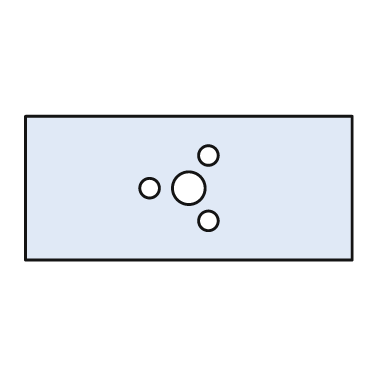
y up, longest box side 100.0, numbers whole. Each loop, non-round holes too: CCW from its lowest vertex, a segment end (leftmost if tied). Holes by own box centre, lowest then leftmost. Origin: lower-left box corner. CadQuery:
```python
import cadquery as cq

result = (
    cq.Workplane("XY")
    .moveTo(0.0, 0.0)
    .lineTo(100.0, 0.0)
    .lineTo(100.0, 44.0)
    .lineTo(0.0, 44.0)
    .close()
    .moveTo(56.0, 12.0)
    .circle(3.0)
    .moveTo(38.0, 22.0)
    .circle(3.0)
    .moveTo(50.0, 22.0)
    .circle(5.0)
    .moveTo(56.0, 32.0)
    .circle(3.0)
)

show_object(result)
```